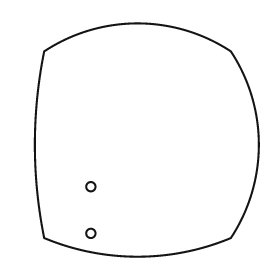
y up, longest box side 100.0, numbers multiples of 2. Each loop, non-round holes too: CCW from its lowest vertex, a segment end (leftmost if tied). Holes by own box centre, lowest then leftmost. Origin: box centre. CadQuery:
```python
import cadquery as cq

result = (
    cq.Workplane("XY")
    .moveTo(-44.0, -42.0)
    .threePointArc((-4.0, -50.0), (36.0, -42.0))
    .threePointArc((48.0, -2.0), (36.0, 38.0))
    .threePointArc((-4.0, 50.0), (-44.0, 38.0))
    .threePointArc((-48.0, -2.0), (-44.0, -42.0))
    .close()
    .moveTo(-24.0, -40.0)
    .circle(2.0)
    .moveTo(-24.0, -20.0)
    .circle(2.0)
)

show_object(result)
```